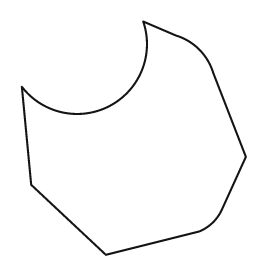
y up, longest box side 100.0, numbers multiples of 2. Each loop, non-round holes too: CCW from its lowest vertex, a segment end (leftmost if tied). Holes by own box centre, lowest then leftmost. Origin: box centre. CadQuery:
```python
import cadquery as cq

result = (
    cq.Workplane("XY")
    .moveTo(-12.0, -50.0)
    .lineTo(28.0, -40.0)
    .threePointArc((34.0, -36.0), (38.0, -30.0))
    .lineTo(48.0, -8.0)
    .lineTo(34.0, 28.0)
    .threePointArc((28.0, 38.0), (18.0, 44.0))
    .lineTo(4.0, 50.0)
    .threePointArc((-10.0, 14.0), (-48.0, 22.0))
    .lineTo(-44.0, -20.0)
    .close()
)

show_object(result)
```